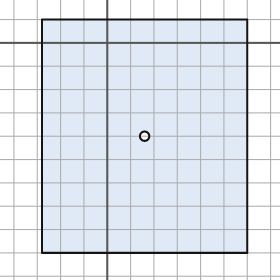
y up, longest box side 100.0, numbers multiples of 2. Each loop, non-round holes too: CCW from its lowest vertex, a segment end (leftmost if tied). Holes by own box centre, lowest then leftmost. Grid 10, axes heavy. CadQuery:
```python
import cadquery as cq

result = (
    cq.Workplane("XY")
    .moveTo(-28.0, -90.0)
    .lineTo(60.0, -90.0)
    .lineTo(60.0, 10.0)
    .lineTo(-28.0, 10.0)
    .close()
    .moveTo(16.0, -40.0)
    .circle(2.0)
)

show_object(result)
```